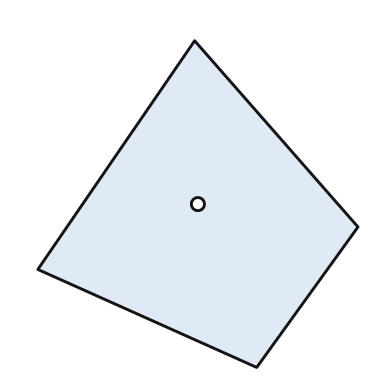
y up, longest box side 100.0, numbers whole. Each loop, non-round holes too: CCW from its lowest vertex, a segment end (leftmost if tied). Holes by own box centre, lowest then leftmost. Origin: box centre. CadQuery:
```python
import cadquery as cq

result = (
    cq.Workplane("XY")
    .moveTo(18.0, -50.0)
    .lineTo(49.0, -7.0)
    .lineTo(-1.0, 50.0)
    .lineTo(-49.0, -20.0)
    .close()
    .moveTo(0.0, 0.0)
    .circle(2.0)
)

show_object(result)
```